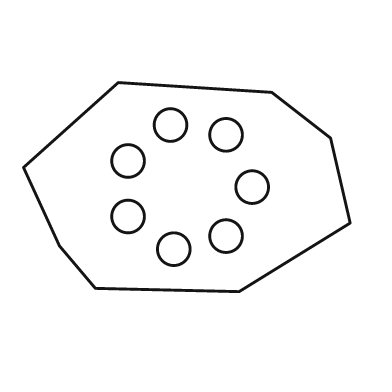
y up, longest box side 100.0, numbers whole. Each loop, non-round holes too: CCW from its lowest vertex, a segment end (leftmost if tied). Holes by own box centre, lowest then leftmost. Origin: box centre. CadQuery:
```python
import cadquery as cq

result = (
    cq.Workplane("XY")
    .moveTo(16.0, -32.0)
    .lineTo(50.0, -11.0)
    .lineTo(44.0, 15.0)
    .lineTo(26.0, 29.0)
    .lineTo(-21.0, 32.0)
    .lineTo(-50.0, 6.0)
    .lineTo(-39.0, -18.0)
    .lineTo(-28.0, -31.0)
    .close()
    .moveTo(-4.0, -19.0)
    .circle(5.0)
    .moveTo(12.0, -15.0)
    .circle(5.0)
    .moveTo(-18.0, -9.0)
    .circle(5.0)
    .moveTo(20.0, 0.0)
    .circle(5.0)
    .moveTo(-18.0, 8.0)
    .circle(5.0)
    .moveTo(12.0, 16.0)
    .circle(5.0)
    .moveTo(-5.0, 19.0)
    .circle(5.0)
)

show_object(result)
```